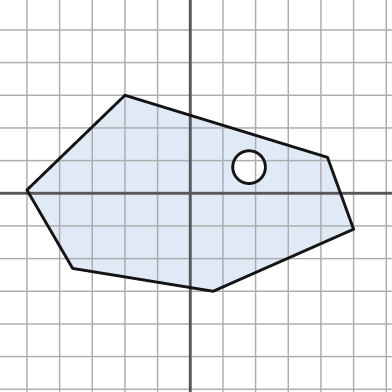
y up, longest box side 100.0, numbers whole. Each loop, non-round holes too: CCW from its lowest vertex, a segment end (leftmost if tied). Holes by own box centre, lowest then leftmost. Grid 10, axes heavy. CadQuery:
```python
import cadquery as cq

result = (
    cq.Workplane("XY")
    .moveTo(7.0, -30.0)
    .lineTo(50.0, -11.0)
    .lineTo(42.0, 11.0)
    .lineTo(-20.0, 30.0)
    .lineTo(-50.0, 1.0)
    .lineTo(-36.0, -23.0)
    .close()
    .moveTo(18.0, 8.0)
    .circle(5.0)
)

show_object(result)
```